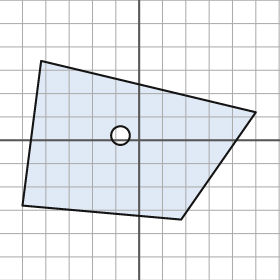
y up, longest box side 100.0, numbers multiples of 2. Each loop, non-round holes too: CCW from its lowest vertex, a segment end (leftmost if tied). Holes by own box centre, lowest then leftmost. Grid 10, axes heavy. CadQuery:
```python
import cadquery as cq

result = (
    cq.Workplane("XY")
    .moveTo(18.0, -34.0)
    .lineTo(50.0, 12.0)
    .lineTo(-42.0, 34.0)
    .lineTo(-50.0, -28.0)
    .close()
    .moveTo(-8.0, 2.0)
    .circle(4.0)
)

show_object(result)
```